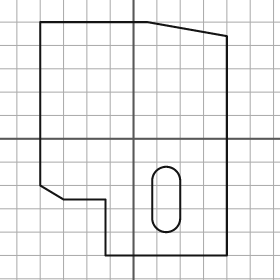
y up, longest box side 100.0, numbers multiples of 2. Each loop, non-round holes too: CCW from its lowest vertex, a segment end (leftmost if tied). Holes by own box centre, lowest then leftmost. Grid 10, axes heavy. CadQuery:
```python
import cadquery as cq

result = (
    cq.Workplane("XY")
    .moveTo(-12.0, -50.0)
    .lineTo(40.0, -50.0)
    .lineTo(40.0, 44.0)
    .lineTo(6.0, 50.0)
    .lineTo(-40.0, 50.0)
    .lineTo(-40.0, -20.0)
    .lineTo(-30.0, -26.0)
    .lineTo(-12.0, -26.0)
    .close()
    .moveTo(8.0, -34.0)
    .threePointArc((14.0, -40.0), (20.0, -34.0))
    .lineTo(20.0, -18.0)
    .threePointArc((14.0, -12.0), (8.0, -18.0))
    .close()
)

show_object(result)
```